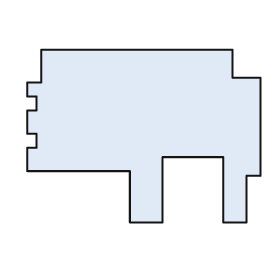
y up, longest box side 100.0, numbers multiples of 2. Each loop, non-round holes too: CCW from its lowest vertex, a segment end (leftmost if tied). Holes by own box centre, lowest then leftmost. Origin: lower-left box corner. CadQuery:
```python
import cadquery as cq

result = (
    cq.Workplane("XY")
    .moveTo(44.0, 0.0)
    .lineTo(58.0, 0.0)
    .lineTo(58.0, 28.0)
    .lineTo(84.0, 28.0)
    .lineTo(84.0, 0.0)
    .lineTo(94.0, 0.0)
    .lineTo(94.0, 20.0)
    .lineTo(100.0, 20.0)
    .lineTo(100.0, 62.0)
    .lineTo(88.0, 62.0)
    .lineTo(88.0, 74.0)
    .lineTo(6.0, 74.0)
    .lineTo(6.0, 60.0)
    .lineTo(0.0, 60.0)
    .lineTo(0.0, 54.0)
    .lineTo(4.0, 54.0)
    .lineTo(4.0, 48.0)
    .lineTo(0.0, 48.0)
    .lineTo(0.0, 38.0)
    .lineTo(4.0, 38.0)
    .lineTo(4.0, 32.0)
    .lineTo(0.0, 32.0)
    .lineTo(0.0, 22.0)
    .lineTo(44.0, 22.0)
    .close()
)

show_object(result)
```